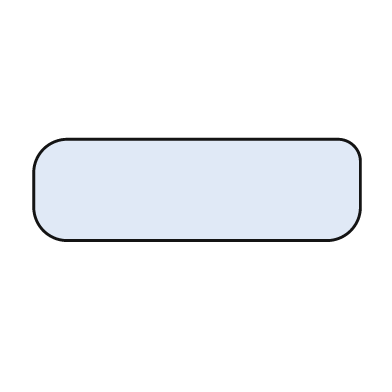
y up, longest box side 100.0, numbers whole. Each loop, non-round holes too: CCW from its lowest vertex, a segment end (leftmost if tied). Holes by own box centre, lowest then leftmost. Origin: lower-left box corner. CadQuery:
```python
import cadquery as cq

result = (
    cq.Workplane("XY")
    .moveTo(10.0, 0.0)
    .lineTo(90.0, 0.0)
    .threePointArc((97.0, 3.0), (100.0, 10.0))
    .lineTo(100.0, 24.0)
    .threePointArc((98.0, 29.0), (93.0, 31.0))
    .lineTo(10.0, 31.0)
    .threePointArc((3.0, 28.0), (0.0, 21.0))
    .lineTo(0.0, 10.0)
    .threePointArc((3.0, 3.0), (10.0, 0.0))
    .close()
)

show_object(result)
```